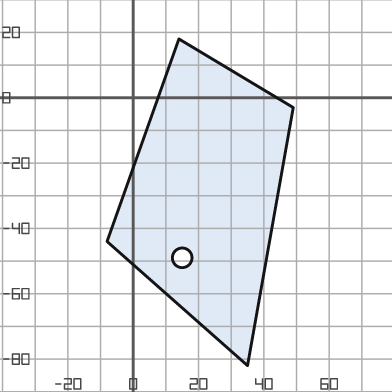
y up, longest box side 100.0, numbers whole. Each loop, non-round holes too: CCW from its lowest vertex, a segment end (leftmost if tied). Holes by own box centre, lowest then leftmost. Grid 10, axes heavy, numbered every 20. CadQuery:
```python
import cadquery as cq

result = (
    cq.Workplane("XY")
    .moveTo(35.0, -82.0)
    .lineTo(49.0, -3.0)
    .lineTo(14.0, 18.0)
    .lineTo(-8.0, -44.0)
    .close()
    .moveTo(15.0, -49.0)
    .circle(3.0)
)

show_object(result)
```